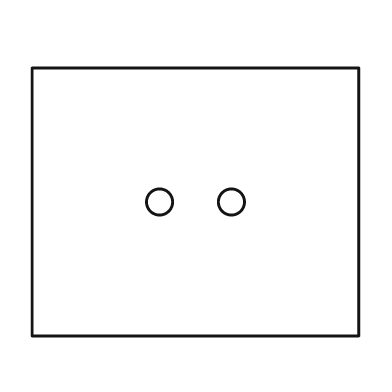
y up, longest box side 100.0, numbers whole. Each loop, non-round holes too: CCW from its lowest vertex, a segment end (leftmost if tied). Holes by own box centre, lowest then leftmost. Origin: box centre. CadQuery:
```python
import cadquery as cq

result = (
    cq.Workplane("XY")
    .moveTo(-50.0, -41.0)
    .lineTo(50.0, -41.0)
    .lineTo(50.0, 41.0)
    .lineTo(-50.0, 41.0)
    .close()
    .moveTo(-11.0, 0.0)
    .circle(4.0)
    .moveTo(11.0, 0.0)
    .circle(4.0)
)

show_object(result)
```